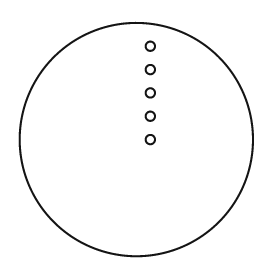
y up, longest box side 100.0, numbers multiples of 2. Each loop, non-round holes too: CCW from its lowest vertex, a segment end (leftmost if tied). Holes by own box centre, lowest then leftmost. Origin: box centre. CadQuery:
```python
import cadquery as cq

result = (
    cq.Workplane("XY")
    .moveTo(0.0, 0.0)
    .circle(50.0)
    .moveTo(6.0, 0.0)
    .circle(2.0)
    .moveTo(6.0, 10.0)
    .circle(2.0)
    .moveTo(6.0, 20.0)
    .circle(2.0)
    .moveTo(6.0, 30.0)
    .circle(2.0)
    .moveTo(6.0, 40.0)
    .circle(2.0)
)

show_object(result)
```